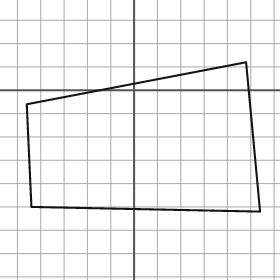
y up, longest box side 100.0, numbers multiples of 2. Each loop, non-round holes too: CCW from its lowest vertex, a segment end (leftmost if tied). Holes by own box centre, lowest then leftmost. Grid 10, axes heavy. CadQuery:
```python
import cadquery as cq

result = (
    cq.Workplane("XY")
    .moveTo(54.0, -52.0)
    .lineTo(48.0, 12.0)
    .lineTo(-46.0, -6.0)
    .lineTo(-44.0, -50.0)
    .close()
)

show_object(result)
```